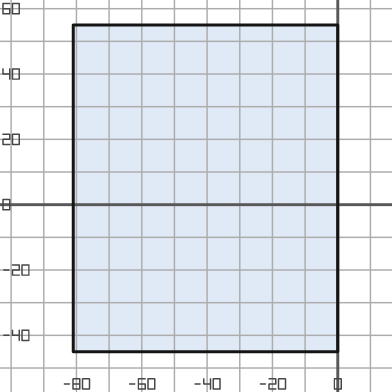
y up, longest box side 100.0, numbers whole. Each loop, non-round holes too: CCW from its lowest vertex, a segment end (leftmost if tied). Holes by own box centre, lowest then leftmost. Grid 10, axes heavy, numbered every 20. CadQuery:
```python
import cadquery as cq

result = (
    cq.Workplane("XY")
    .moveTo(-81.0, -45.0)
    .lineTo(0.0, -45.0)
    .lineTo(0.0, 55.0)
    .lineTo(-81.0, 55.0)
    .close()
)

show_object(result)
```